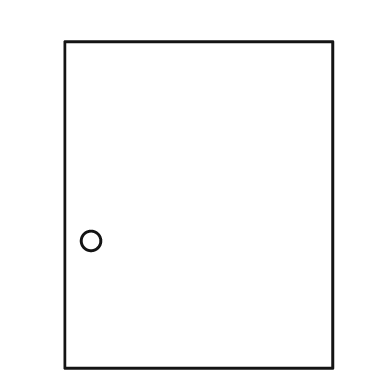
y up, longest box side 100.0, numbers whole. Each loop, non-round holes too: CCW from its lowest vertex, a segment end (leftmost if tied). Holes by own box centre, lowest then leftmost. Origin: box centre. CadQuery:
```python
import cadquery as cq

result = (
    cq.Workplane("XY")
    .moveTo(-41.0, -50.0)
    .lineTo(41.0, -50.0)
    .lineTo(41.0, 50.0)
    .lineTo(-41.0, 50.0)
    .close()
    .moveTo(-33.0, -11.0)
    .circle(3.0)
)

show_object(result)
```